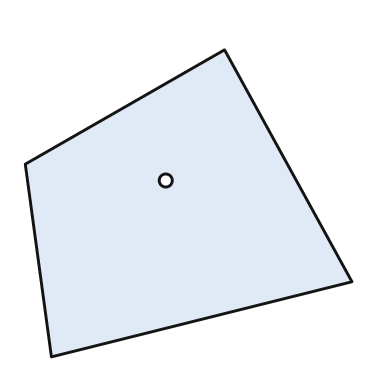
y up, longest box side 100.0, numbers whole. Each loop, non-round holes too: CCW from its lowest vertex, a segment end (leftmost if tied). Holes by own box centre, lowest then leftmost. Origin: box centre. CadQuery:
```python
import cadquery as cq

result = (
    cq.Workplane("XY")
    .moveTo(-42.0, -47.0)
    .lineTo(50.0, -24.0)
    .lineTo(11.0, 47.0)
    .lineTo(-50.0, 12.0)
    .close()
    .moveTo(-7.0, 7.0)
    .circle(2.0)
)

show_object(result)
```